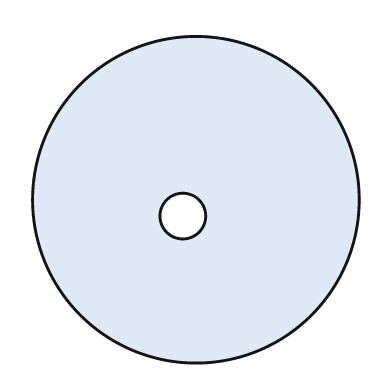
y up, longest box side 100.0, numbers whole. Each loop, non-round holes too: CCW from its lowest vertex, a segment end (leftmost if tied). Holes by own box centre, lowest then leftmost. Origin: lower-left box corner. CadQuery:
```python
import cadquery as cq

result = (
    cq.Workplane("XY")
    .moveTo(50.0, 50.0)
    .circle(50.0)
    .moveTo(46.0, 45.0)
    .circle(7.0)
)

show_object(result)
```